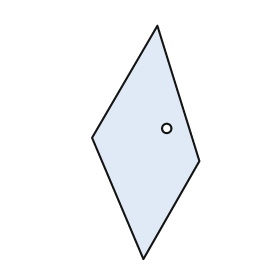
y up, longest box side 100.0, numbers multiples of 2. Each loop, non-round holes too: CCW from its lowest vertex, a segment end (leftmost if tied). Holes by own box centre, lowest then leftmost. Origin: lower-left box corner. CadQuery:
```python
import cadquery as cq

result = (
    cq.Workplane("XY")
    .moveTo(22.0, 0.0)
    .lineTo(46.0, 42.0)
    .lineTo(28.0, 100.0)
    .lineTo(0.0, 52.0)
    .close()
    .moveTo(32.0, 56.0)
    .circle(2.0)
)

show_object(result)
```